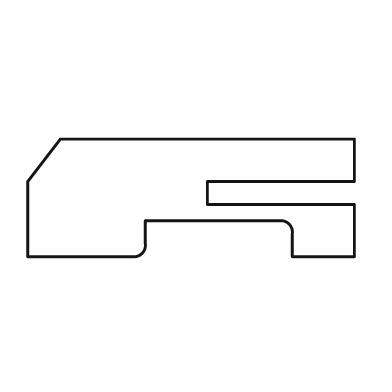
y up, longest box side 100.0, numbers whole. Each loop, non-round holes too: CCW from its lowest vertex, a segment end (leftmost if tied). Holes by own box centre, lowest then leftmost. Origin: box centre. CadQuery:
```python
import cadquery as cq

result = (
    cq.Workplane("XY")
    .moveTo(-50.0, -18.0)
    .lineTo(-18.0, -18.0)
    .threePointArc((-15.0, -17.0), (-14.0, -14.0))
    .lineTo(-14.0, -7.0)
    .lineTo(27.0, -7.0)
    .threePointArc((30.0, -8.0), (31.0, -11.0))
    .lineTo(31.0, -18.0)
    .lineTo(50.0, -18.0)
    .lineTo(50.0, -2.0)
    .lineTo(5.0, -2.0)
    .lineTo(5.0, 5.0)
    .lineTo(50.0, 5.0)
    .lineTo(50.0, 18.0)
    .lineTo(-40.0, 18.0)
    .lineTo(-50.0, 5.0)
    .close()
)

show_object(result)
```